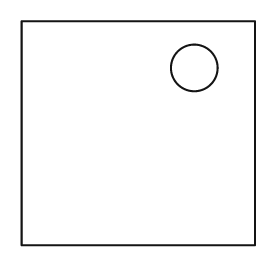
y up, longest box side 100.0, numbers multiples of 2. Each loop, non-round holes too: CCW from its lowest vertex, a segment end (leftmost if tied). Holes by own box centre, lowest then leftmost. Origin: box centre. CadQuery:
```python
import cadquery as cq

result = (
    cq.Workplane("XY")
    .moveTo(-50.0, -48.0)
    .lineTo(50.0, -48.0)
    .lineTo(50.0, 48.0)
    .lineTo(-50.0, 48.0)
    .close()
    .moveTo(24.0, 28.0)
    .circle(10.0)
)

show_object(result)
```